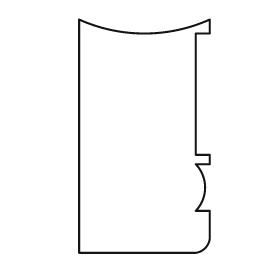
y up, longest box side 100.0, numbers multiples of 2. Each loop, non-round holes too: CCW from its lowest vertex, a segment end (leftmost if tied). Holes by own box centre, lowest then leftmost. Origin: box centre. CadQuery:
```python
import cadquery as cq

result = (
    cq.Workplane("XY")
    .moveTo(-28.0, -50.0)
    .lineTo(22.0, -50.0)
    .threePointArc((26.0, -48.0), (28.0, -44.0))
    .lineTo(28.0, -32.0)
    .lineTo(22.0, -32.0)
    .threePointArc((26.0, -22.0), (22.0, -12.0))
    .lineTo(28.0, -12.0)
    .lineTo(28.0, -8.0)
    .lineTo(22.0, -8.0)
    .lineTo(22.0, 44.0)
    .lineTo(28.0, 44.0)
    .lineTo(28.0, 50.0)
    .threePointArc((0.0, 44.0), (-28.0, 50.0))
    .close()
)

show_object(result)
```